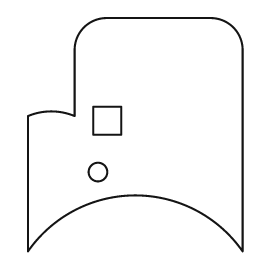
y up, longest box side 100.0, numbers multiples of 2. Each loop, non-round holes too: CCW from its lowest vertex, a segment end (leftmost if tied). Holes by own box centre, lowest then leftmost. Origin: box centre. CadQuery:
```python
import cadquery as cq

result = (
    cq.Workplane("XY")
    .moveTo(-46.0, -50.0)
    .threePointArc((0.0, -26.0), (46.0, -50.0))
    .lineTo(46.0, 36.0)
    .threePointArc((42.0, 46.0), (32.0, 50.0))
    .lineTo(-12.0, 50.0)
    .threePointArc((-22.0, 46.0), (-26.0, 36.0))
    .lineTo(-26.0, 8.0)
    .threePointArc((-36.0, 10.0), (-46.0, 8.0))
    .close()
    .moveTo(-16.0, -16.0)
    .circle(4.0)
    .moveTo(-18.0, 0.0)
    .lineTo(-6.0, 0.0)
    .lineTo(-6.0, 12.0)
    .lineTo(-18.0, 12.0)
    .close()
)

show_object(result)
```